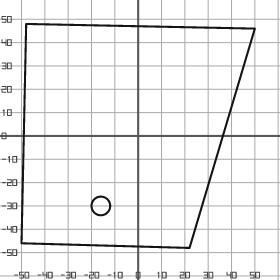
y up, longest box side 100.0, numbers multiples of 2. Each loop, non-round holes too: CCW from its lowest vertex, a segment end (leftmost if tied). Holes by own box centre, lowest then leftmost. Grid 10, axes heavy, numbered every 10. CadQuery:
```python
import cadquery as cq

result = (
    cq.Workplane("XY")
    .moveTo(22.0, -48.0)
    .lineTo(50.0, 46.0)
    .lineTo(-48.0, 48.0)
    .lineTo(-50.0, -46.0)
    .close()
    .moveTo(-16.0, -30.0)
    .circle(4.0)
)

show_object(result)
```